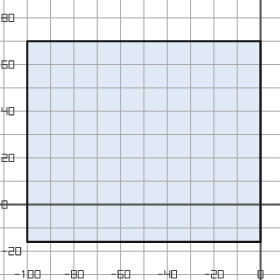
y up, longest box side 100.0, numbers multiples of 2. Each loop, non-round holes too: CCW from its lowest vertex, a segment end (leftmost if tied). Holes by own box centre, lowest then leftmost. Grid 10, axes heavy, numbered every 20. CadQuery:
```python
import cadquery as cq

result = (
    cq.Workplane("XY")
    .moveTo(-100.0, -16.0)
    .lineTo(0.0, -16.0)
    .lineTo(0.0, 70.0)
    .lineTo(-100.0, 70.0)
    .close()
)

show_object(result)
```